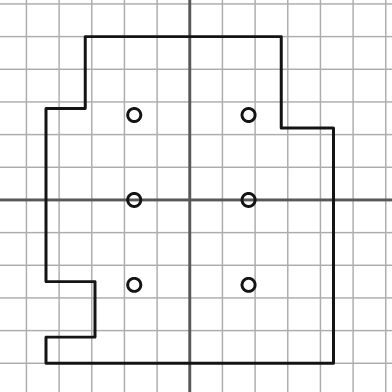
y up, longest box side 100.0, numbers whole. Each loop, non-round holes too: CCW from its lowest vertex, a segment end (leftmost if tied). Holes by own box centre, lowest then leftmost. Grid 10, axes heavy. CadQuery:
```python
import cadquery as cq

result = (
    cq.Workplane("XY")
    .moveTo(-44.0, -50.0)
    .lineTo(44.0, -50.0)
    .lineTo(44.0, 22.0)
    .lineTo(28.0, 22.0)
    .lineTo(28.0, 50.0)
    .lineTo(-32.0, 50.0)
    .lineTo(-32.0, 28.0)
    .lineTo(-44.0, 28.0)
    .lineTo(-44.0, -25.0)
    .lineTo(-29.0, -25.0)
    .lineTo(-29.0, -42.0)
    .lineTo(-44.0, -42.0)
    .close()
    .moveTo(-17.0, -26.0)
    .circle(2.0)
    .moveTo(18.0, -26.0)
    .circle(2.0)
    .moveTo(-17.0, 0.0)
    .circle(2.0)
    .moveTo(18.0, 0.0)
    .circle(2.0)
    .moveTo(-17.0, 26.0)
    .circle(2.0)
    .moveTo(18.0, 26.0)
    .circle(2.0)
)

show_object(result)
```